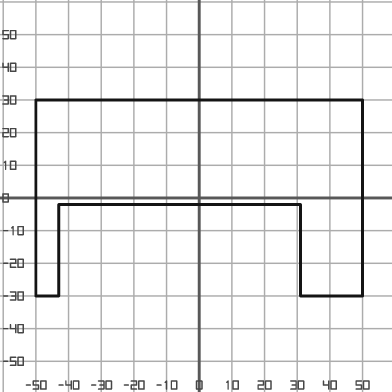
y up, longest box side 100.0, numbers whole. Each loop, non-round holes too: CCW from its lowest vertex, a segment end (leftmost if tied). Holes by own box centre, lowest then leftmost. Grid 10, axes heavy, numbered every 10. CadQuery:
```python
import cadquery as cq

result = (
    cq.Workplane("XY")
    .moveTo(-50.0, -30.0)
    .lineTo(-43.0, -30.0)
    .lineTo(-43.0, -2.0)
    .lineTo(31.0, -2.0)
    .lineTo(31.0, -30.0)
    .lineTo(50.0, -30.0)
    .lineTo(50.0, 30.0)
    .lineTo(-50.0, 30.0)
    .close()
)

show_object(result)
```